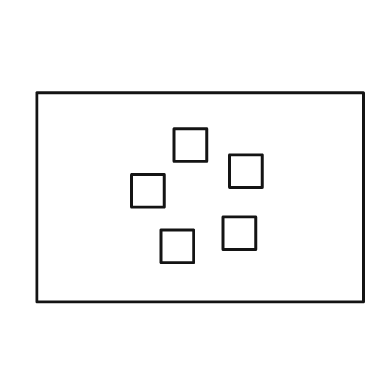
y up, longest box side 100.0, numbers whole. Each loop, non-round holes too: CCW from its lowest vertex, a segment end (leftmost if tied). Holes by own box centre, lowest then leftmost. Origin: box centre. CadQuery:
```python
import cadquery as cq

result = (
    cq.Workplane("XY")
    .moveTo(-50.0, -32.0)
    .lineTo(50.0, -32.0)
    .lineTo(50.0, 32.0)
    .lineTo(-50.0, 32.0)
    .close()
    .moveTo(-12.0, -20.0)
    .lineTo(-2.0, -20.0)
    .lineTo(-2.0, -10.0)
    .lineTo(-12.0, -10.0)
    .close()
    .moveTo(7.0, -16.0)
    .lineTo(17.0, -16.0)
    .lineTo(17.0, -6.0)
    .lineTo(7.0, -6.0)
    .close()
    .moveTo(-21.0, -3.0)
    .lineTo(-11.0, -3.0)
    .lineTo(-11.0, 7.0)
    .lineTo(-21.0, 7.0)
    .close()
    .moveTo(9.0, 3.0)
    .lineTo(19.0, 3.0)
    .lineTo(19.0, 13.0)
    .lineTo(9.0, 13.0)
    .close()
    .moveTo(-8.0, 11.0)
    .lineTo(2.0, 11.0)
    .lineTo(2.0, 21.0)
    .lineTo(-8.0, 21.0)
    .close()
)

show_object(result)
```